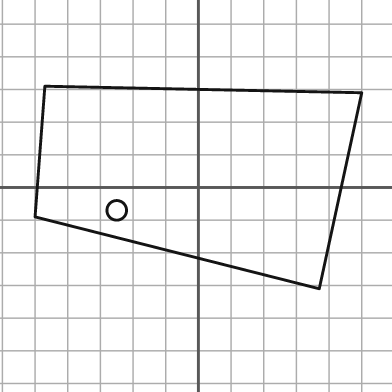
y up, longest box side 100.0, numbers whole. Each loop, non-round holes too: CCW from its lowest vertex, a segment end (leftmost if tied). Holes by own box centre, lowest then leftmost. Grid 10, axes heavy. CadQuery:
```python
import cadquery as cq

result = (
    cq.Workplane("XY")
    .moveTo(37.0, -31.0)
    .lineTo(50.0, 29.0)
    .lineTo(-47.0, 31.0)
    .lineTo(-50.0, -9.0)
    .close()
    .moveTo(-25.0, -7.0)
    .circle(3.0)
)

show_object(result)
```